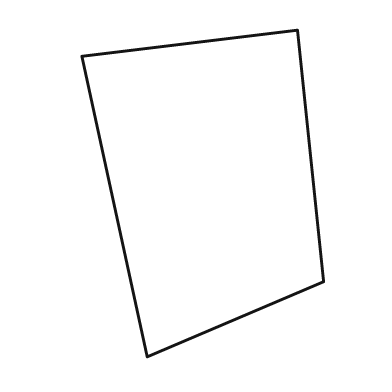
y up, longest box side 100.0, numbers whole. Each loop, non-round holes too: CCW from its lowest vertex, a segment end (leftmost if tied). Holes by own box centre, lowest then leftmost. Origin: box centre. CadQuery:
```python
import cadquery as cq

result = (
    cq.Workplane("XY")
    .moveTo(-17.0, -50.0)
    .lineTo(37.0, -27.0)
    .lineTo(29.0, 50.0)
    .lineTo(-37.0, 42.0)
    .close()
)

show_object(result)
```